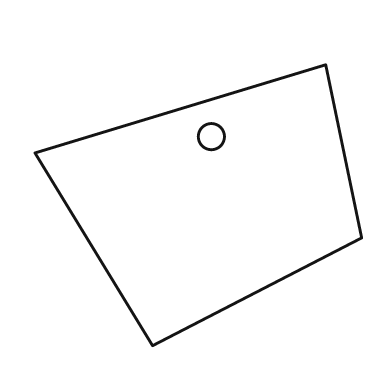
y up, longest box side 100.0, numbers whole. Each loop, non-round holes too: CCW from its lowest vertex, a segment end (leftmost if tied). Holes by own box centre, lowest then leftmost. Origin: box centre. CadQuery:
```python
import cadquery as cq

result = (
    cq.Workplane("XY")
    .moveTo(-14.0, -43.0)
    .lineTo(50.0, -10.0)
    .lineTo(39.0, 43.0)
    .lineTo(-50.0, 16.0)
    .close()
    .moveTo(4.0, 21.0)
    .circle(4.0)
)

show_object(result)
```